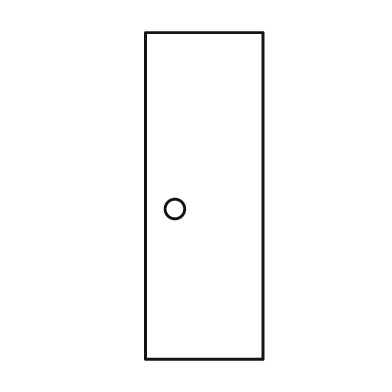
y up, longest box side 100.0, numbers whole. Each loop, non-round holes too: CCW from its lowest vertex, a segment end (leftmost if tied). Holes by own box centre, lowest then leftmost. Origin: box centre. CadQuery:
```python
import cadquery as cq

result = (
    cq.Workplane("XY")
    .moveTo(-18.0, -50.0)
    .lineTo(18.0, -50.0)
    .lineTo(18.0, 50.0)
    .lineTo(-18.0, 50.0)
    .close()
    .moveTo(-9.0, -4.0)
    .circle(3.0)
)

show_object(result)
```